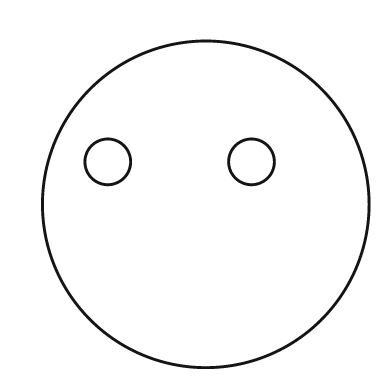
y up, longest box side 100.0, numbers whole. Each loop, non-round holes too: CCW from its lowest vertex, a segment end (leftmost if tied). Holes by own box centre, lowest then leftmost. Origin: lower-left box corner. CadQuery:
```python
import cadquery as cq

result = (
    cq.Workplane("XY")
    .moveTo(50.0, 50.0)
    .circle(50.0)
    .moveTo(20.0, 63.0)
    .circle(7.0)
    .moveTo(64.0, 63.0)
    .circle(7.0)
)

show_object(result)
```